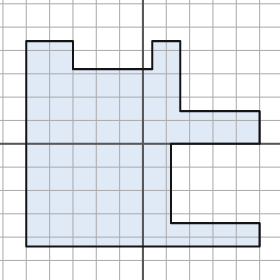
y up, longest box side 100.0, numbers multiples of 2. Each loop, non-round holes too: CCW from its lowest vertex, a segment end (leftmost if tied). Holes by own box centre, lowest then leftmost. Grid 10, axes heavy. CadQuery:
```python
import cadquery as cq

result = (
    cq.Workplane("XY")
    .moveTo(-50.0, -44.0)
    .lineTo(50.0, -44.0)
    .lineTo(50.0, -34.0)
    .lineTo(12.0, -34.0)
    .lineTo(12.0, 0.0)
    .lineTo(50.0, 0.0)
    .lineTo(50.0, 14.0)
    .lineTo(16.0, 14.0)
    .lineTo(16.0, 44.0)
    .lineTo(4.0, 44.0)
    .lineTo(4.0, 32.0)
    .lineTo(-30.0, 32.0)
    .lineTo(-30.0, 44.0)
    .lineTo(-50.0, 44.0)
    .close()
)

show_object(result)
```